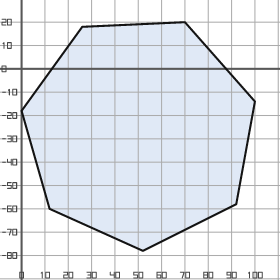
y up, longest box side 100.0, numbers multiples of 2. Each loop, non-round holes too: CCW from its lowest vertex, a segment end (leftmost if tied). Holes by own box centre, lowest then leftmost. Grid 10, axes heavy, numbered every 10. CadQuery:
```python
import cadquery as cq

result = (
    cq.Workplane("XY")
    .moveTo(52.0, -78.0)
    .lineTo(92.0, -58.0)
    .lineTo(100.0, -14.0)
    .lineTo(70.0, 20.0)
    .lineTo(26.0, 18.0)
    .lineTo(0.0, -18.0)
    .lineTo(12.0, -60.0)
    .close()
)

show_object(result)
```